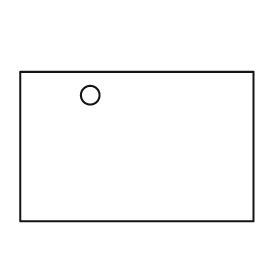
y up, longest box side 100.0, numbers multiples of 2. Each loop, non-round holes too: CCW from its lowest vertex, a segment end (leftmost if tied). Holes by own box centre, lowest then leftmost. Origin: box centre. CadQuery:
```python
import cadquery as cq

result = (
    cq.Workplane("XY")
    .moveTo(-50.0, -32.0)
    .lineTo(50.0, -32.0)
    .lineTo(50.0, 32.0)
    .lineTo(-50.0, 32.0)
    .close()
    .moveTo(-20.0, 22.0)
    .circle(4.0)
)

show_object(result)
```